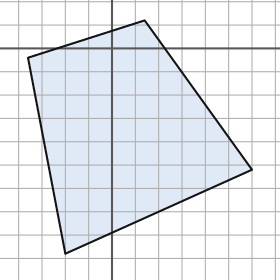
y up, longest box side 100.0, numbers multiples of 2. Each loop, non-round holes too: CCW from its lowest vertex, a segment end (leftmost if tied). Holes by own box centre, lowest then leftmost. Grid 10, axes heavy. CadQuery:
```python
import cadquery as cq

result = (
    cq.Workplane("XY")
    .moveTo(-20.0, -88.0)
    .lineTo(60.0, -52.0)
    .lineTo(14.0, 12.0)
    .lineTo(-36.0, -4.0)
    .close()
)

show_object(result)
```